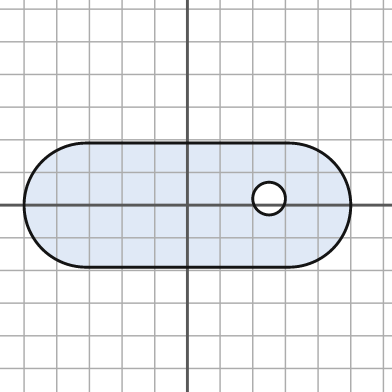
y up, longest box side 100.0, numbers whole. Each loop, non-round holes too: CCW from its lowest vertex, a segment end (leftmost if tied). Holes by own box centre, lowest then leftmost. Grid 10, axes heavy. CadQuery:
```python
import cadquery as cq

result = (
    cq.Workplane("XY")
    .moveTo(-31.0, -19.0)
    .lineTo(31.0, -19.0)
    .threePointArc((50.0, 0.0), (31.0, 19.0))
    .lineTo(-31.0, 19.0)
    .threePointArc((-50.0, 0.0), (-31.0, -19.0))
    .close()
    .moveTo(25.0, 2.0)
    .circle(5.0)
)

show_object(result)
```